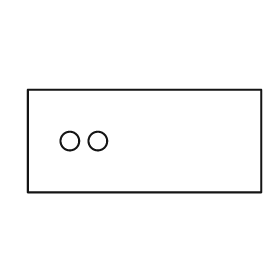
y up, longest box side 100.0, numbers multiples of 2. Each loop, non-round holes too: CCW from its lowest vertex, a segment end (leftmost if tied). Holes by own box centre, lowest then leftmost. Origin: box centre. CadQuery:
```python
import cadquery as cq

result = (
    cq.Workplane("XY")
    .moveTo(-50.0, -22.0)
    .lineTo(50.0, -22.0)
    .lineTo(50.0, 22.0)
    .lineTo(-50.0, 22.0)
    .close()
    .moveTo(-32.0, 0.0)
    .circle(4.0)
    .moveTo(-20.0, 0.0)
    .circle(4.0)
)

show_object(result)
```